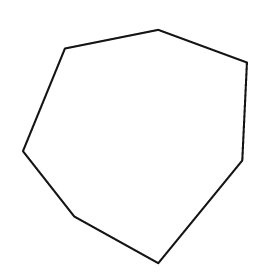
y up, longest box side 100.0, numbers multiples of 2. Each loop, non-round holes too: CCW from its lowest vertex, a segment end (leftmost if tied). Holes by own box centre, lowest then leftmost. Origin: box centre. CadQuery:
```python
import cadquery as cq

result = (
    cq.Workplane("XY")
    .moveTo(10.0, -50.0)
    .lineTo(46.0, -6.0)
    .lineTo(48.0, 36.0)
    .lineTo(10.0, 50.0)
    .lineTo(-30.0, 42.0)
    .lineTo(-48.0, -2.0)
    .lineTo(-26.0, -30.0)
    .close()
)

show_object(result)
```